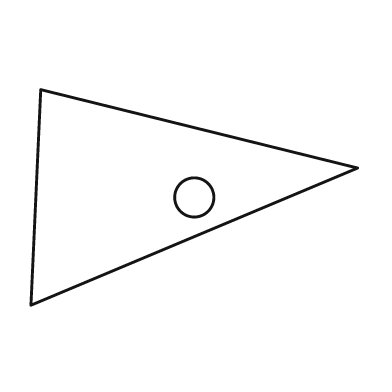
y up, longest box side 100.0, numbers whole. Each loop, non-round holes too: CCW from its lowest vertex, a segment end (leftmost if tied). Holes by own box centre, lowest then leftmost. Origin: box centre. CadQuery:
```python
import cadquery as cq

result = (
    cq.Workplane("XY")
    .moveTo(-50.0, -33.0)
    .lineTo(50.0, 9.0)
    .lineTo(-47.0, 33.0)
    .close()
    .moveTo(0.0, 0.0)
    .circle(6.0)
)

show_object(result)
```